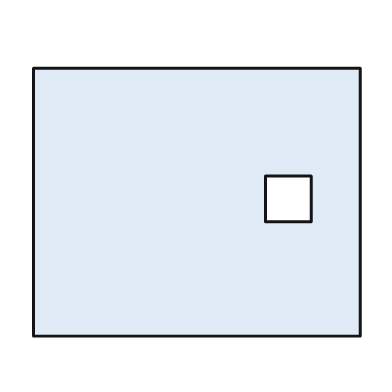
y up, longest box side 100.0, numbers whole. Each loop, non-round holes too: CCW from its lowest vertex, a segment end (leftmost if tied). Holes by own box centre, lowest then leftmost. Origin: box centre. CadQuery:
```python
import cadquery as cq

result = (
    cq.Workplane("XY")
    .moveTo(-50.0, -41.0)
    .lineTo(50.0, -41.0)
    .lineTo(50.0, 41.0)
    .lineTo(-50.0, 41.0)
    .close()
    .moveTo(21.0, -6.0)
    .lineTo(35.0, -6.0)
    .lineTo(35.0, 8.0)
    .lineTo(21.0, 8.0)
    .close()
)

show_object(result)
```